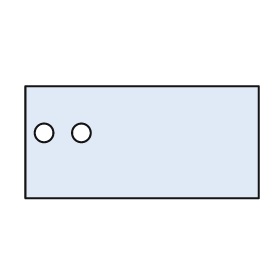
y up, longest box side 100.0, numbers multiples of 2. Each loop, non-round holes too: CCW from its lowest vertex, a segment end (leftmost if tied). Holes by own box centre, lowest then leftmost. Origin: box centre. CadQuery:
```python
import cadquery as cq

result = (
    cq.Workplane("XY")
    .moveTo(-50.0, -24.0)
    .lineTo(50.0, -24.0)
    .lineTo(50.0, 24.0)
    .lineTo(-50.0, 24.0)
    .close()
    .moveTo(-42.0, 4.0)
    .circle(4.0)
    .moveTo(-26.0, 4.0)
    .circle(4.0)
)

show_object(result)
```